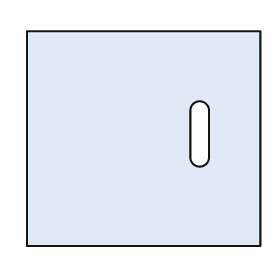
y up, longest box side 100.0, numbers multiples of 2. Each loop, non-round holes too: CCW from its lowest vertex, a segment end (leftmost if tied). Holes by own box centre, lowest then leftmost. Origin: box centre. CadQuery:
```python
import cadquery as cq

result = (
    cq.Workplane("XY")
    .moveTo(-50.0, -46.0)
    .lineTo(50.0, -46.0)
    .lineTo(50.0, 46.0)
    .lineTo(-50.0, 46.0)
    .close()
    .moveTo(20.0, -8.0)
    .threePointArc((24.0, -12.0), (28.0, -8.0))
    .lineTo(28.0, 12.0)
    .threePointArc((24.0, 16.0), (20.0, 12.0))
    .close()
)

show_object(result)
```